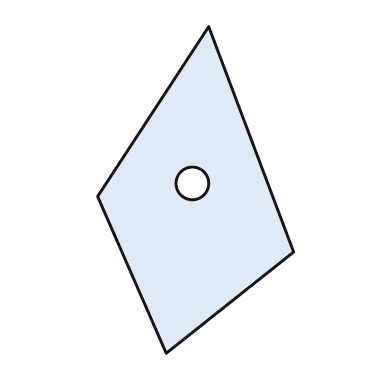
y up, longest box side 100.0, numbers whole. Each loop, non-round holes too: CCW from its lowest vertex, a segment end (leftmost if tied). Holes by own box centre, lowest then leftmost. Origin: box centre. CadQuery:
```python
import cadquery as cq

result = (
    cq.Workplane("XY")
    .moveTo(-9.0, -50.0)
    .lineTo(30.0, -19.0)
    .lineTo(4.0, 50.0)
    .lineTo(-30.0, -2.0)
    .close()
    .moveTo(-1.0, 2.0)
    .circle(5.0)
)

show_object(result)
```